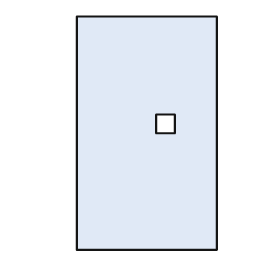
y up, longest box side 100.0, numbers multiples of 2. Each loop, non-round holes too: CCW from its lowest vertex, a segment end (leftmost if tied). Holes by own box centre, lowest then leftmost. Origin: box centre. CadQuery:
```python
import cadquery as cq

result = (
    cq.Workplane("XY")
    .moveTo(-30.0, -50.0)
    .lineTo(30.0, -50.0)
    .lineTo(30.0, 50.0)
    .lineTo(-30.0, 50.0)
    .close()
    .moveTo(4.0, 0.0)
    .lineTo(12.0, 0.0)
    .lineTo(12.0, 8.0)
    .lineTo(4.0, 8.0)
    .close()
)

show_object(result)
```